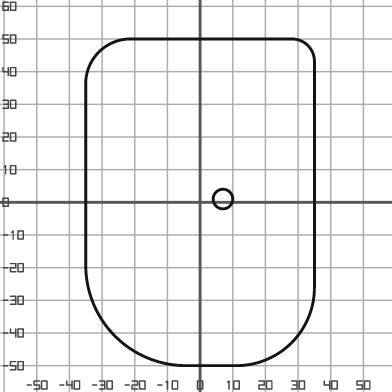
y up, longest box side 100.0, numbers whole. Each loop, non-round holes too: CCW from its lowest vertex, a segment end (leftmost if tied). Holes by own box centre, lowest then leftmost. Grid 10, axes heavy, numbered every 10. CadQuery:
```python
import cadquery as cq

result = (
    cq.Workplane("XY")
    .moveTo(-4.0, -50.0)
    .lineTo(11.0, -50.0)
    .threePointArc((28.0, -43.0), (35.0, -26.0))
    .lineTo(35.0, 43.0)
    .threePointArc((33.0, 48.0), (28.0, 50.0))
    .lineTo(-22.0, 50.0)
    .threePointArc((-31.0, 46.0), (-35.0, 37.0))
    .lineTo(-35.0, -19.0)
    .threePointArc((-26.0, -41.0), (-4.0, -50.0))
    .close()
    .moveTo(7.0, 1.0)
    .circle(3.0)
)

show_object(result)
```